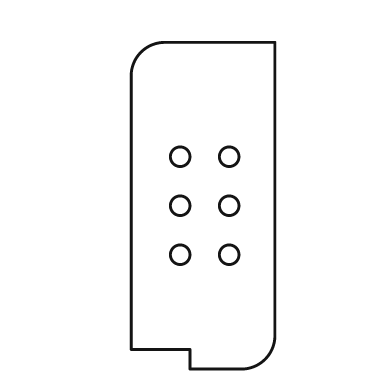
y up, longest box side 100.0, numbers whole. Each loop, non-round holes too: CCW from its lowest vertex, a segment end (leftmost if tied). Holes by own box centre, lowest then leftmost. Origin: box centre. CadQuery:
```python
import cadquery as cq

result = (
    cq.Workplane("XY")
    .moveTo(-4.0, -50.0)
    .lineTo(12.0, -50.0)
    .threePointArc((19.0, -47.0), (22.0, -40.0))
    .lineTo(22.0, 50.0)
    .lineTo(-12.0, 50.0)
    .threePointArc((-19.0, 47.0), (-22.0, 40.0))
    .lineTo(-22.0, -44.0)
    .lineTo(-4.0, -44.0)
    .close()
    .moveTo(-7.0, -15.0)
    .circle(3.0)
    .moveTo(8.0, -15.0)
    .circle(3.0)
    .moveTo(-7.0, 0.0)
    .circle(3.0)
    .moveTo(8.0, 0.0)
    .circle(3.0)
    .moveTo(-7.0, 15.0)
    .circle(3.0)
    .moveTo(8.0, 15.0)
    .circle(3.0)
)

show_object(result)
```